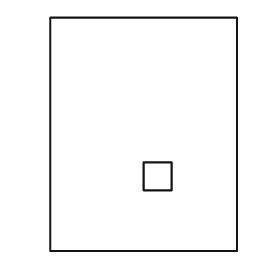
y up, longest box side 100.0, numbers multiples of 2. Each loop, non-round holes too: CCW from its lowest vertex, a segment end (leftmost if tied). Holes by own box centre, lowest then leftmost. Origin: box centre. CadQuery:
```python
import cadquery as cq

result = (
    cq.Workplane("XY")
    .moveTo(-40.0, -50.0)
    .lineTo(40.0, -50.0)
    .lineTo(40.0, 50.0)
    .lineTo(-40.0, 50.0)
    .close()
    .moveTo(0.0, -24.0)
    .lineTo(12.0, -24.0)
    .lineTo(12.0, -12.0)
    .lineTo(0.0, -12.0)
    .close()
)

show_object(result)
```